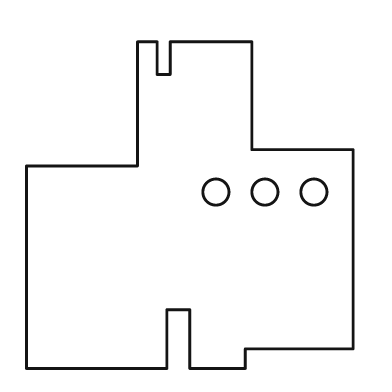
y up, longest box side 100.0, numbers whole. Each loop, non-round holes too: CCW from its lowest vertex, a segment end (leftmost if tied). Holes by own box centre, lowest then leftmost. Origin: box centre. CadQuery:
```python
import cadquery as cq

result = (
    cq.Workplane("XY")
    .moveTo(-50.0, -50.0)
    .lineTo(-7.0, -50.0)
    .lineTo(-7.0, -32.0)
    .lineTo(0.0, -32.0)
    .lineTo(0.0, -50.0)
    .lineTo(17.0, -50.0)
    .lineTo(17.0, -44.0)
    .lineTo(50.0, -44.0)
    .lineTo(50.0, 17.0)
    .lineTo(19.0, 17.0)
    .lineTo(19.0, 50.0)
    .lineTo(-6.0, 50.0)
    .lineTo(-6.0, 40.0)
    .lineTo(-10.0, 40.0)
    .lineTo(-10.0, 50.0)
    .lineTo(-16.0, 50.0)
    .lineTo(-16.0, 12.0)
    .lineTo(-50.0, 12.0)
    .close()
    .moveTo(8.0, 4.0)
    .circle(4.0)
    .moveTo(23.0, 4.0)
    .circle(4.0)
    .moveTo(38.0, 4.0)
    .circle(4.0)
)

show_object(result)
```